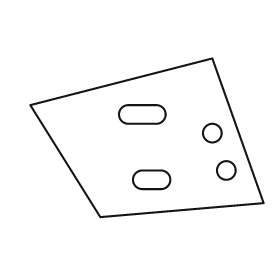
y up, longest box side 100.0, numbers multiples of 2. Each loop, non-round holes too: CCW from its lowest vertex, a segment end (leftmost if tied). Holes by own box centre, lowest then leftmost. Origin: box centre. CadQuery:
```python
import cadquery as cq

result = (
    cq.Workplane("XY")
    .moveTo(-20.0, -34.0)
    .lineTo(50.0, -28.0)
    .lineTo(28.0, 34.0)
    .lineTo(-50.0, 14.0)
    .close()
    .moveTo(-2.0, -22.0)
    .lineTo(6.0, -22.0)
    .threePointArc((10.0, -18.0), (6.0, -14.0))
    .lineTo(-2.0, -14.0)
    .threePointArc((-6.0, -18.0), (-2.0, -22.0))
    .close()
    .moveTo(34.0, -14.0)
    .circle(4.0)
    .moveTo(28.0, 2.0)
    .circle(4.0)
    .moveTo(-8.0, 6.0)
    .lineTo(4.0, 6.0)
    .threePointArc((8.0, 10.0), (4.0, 14.0))
    .lineTo(-8.0, 14.0)
    .threePointArc((-12.0, 10.0), (-8.0, 6.0))
    .close()
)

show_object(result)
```